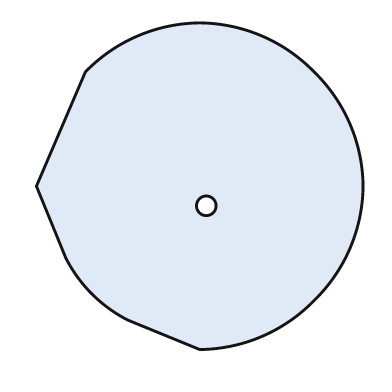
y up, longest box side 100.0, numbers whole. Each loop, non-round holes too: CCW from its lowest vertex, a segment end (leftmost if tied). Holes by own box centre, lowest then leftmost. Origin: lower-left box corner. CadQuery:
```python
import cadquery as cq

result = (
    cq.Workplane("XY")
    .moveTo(50.0, 0.0)
    .threePointArc((69.0, 4.0), (85.0, 15.0))
    .threePointArc((96.0, 31.0), (100.0, 50.0))
    .threePointArc((96.0, 69.0), (85.0, 85.0))
    .threePointArc((69.0, 96.0), (50.0, 100.0))
    .threePointArc((31.0, 96.0), (15.0, 85.0))
    .lineTo(0.0, 50.0)
    .lineTo(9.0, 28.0)
    .threePointArc((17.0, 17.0), (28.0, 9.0))
    .close()
    .moveTo(52.0, 44.0)
    .circle(3.0)
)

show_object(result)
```